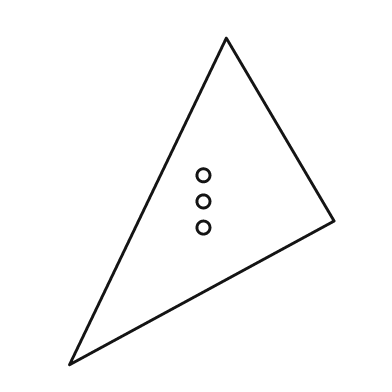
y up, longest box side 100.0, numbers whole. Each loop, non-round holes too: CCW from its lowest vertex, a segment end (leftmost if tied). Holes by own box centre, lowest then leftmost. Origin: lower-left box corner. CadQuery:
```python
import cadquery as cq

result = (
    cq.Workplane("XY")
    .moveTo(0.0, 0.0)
    .lineTo(81.0, 44.0)
    .lineTo(48.0, 100.0)
    .close()
    .moveTo(41.0, 42.0)
    .circle(2.0)
    .moveTo(41.0, 50.0)
    .circle(2.0)
    .moveTo(41.0, 58.0)
    .circle(2.0)
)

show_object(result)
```